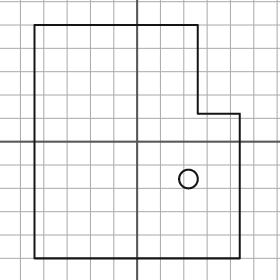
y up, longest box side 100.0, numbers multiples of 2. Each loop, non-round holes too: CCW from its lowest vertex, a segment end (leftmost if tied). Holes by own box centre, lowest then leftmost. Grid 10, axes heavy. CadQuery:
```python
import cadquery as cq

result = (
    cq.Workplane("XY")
    .moveTo(-44.0, -50.0)
    .lineTo(44.0, -50.0)
    .lineTo(44.0, 12.0)
    .lineTo(26.0, 12.0)
    .lineTo(26.0, 50.0)
    .lineTo(-44.0, 50.0)
    .close()
    .moveTo(22.0, -16.0)
    .circle(4.0)
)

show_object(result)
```